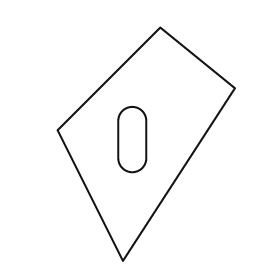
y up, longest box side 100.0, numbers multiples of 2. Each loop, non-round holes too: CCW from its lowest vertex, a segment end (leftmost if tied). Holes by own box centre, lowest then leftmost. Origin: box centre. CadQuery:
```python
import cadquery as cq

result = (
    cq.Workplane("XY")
    .moveTo(-10.0, -50.0)
    .lineTo(38.0, 24.0)
    .lineTo(6.0, 50.0)
    .lineTo(-38.0, 6.0)
    .close()
    .moveTo(-12.0, -6.0)
    .threePointArc((-6.0, -12.0), (0.0, -6.0))
    .lineTo(0.0, 10.0)
    .threePointArc((-6.0, 16.0), (-12.0, 10.0))
    .close()
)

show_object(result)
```